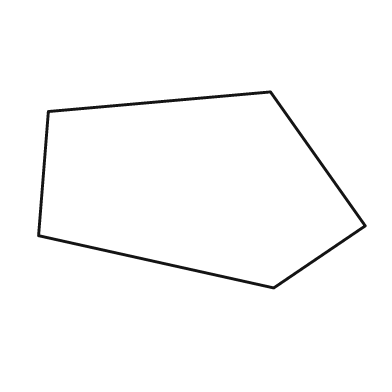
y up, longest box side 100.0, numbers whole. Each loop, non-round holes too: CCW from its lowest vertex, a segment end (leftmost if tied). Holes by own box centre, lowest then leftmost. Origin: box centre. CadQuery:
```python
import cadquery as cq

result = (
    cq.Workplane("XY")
    .moveTo(22.0, -30.0)
    .lineTo(50.0, -11.0)
    .lineTo(21.0, 30.0)
    .lineTo(-47.0, 24.0)
    .lineTo(-50.0, -14.0)
    .close()
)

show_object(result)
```